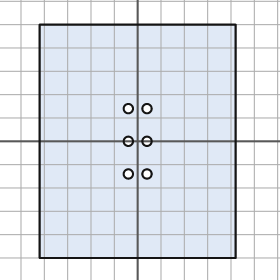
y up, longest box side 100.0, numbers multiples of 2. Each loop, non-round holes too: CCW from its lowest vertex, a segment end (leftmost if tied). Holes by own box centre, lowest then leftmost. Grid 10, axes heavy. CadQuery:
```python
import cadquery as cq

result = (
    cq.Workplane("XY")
    .moveTo(-42.0, -50.0)
    .lineTo(42.0, -50.0)
    .lineTo(42.0, 50.0)
    .lineTo(-42.0, 50.0)
    .close()
    .moveTo(-4.0, -14.0)
    .circle(2.0)
    .moveTo(4.0, -14.0)
    .circle(2.0)
    .moveTo(-4.0, 0.0)
    .circle(2.0)
    .moveTo(4.0, 0.0)
    .circle(2.0)
    .moveTo(-4.0, 14.0)
    .circle(2.0)
    .moveTo(4.0, 14.0)
    .circle(2.0)
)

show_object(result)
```